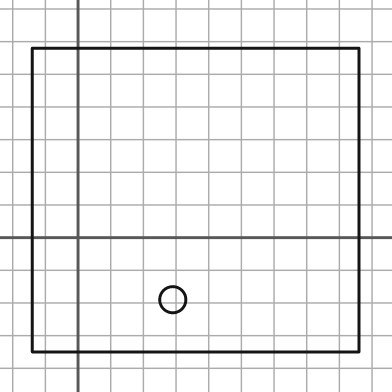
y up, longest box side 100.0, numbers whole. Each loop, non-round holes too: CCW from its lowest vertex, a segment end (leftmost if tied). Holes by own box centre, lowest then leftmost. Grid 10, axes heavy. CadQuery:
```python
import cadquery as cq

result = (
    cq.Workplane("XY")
    .moveTo(-14.0, -35.0)
    .lineTo(86.0, -35.0)
    .lineTo(86.0, 58.0)
    .lineTo(-14.0, 58.0)
    .close()
    .moveTo(29.0, -19.0)
    .circle(4.0)
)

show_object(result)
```